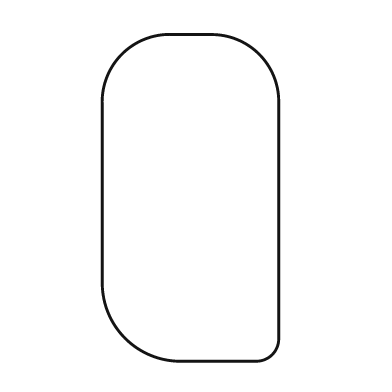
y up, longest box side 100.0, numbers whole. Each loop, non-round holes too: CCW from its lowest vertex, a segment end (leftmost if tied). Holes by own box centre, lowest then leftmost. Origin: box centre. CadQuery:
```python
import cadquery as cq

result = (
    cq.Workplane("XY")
    .moveTo(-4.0, -50.0)
    .lineTo(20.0, -50.0)
    .threePointArc((25.0, -48.0), (27.0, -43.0))
    .lineTo(27.0, 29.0)
    .threePointArc((21.0, 44.0), (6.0, 50.0))
    .lineTo(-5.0, 50.0)
    .threePointArc((-21.0, 44.0), (-27.0, 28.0))
    .lineTo(-27.0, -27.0)
    .threePointArc((-20.0, -43.0), (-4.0, -50.0))
    .close()
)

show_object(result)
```